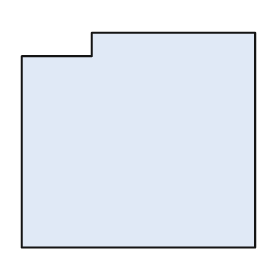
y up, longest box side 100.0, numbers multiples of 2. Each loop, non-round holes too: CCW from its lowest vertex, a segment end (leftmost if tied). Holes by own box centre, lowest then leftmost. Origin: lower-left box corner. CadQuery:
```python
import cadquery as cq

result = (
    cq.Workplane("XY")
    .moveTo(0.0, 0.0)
    .lineTo(100.0, 0.0)
    .lineTo(100.0, 92.0)
    .lineTo(30.0, 92.0)
    .lineTo(30.0, 82.0)
    .lineTo(0.0, 82.0)
    .close()
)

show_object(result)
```